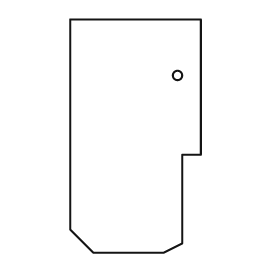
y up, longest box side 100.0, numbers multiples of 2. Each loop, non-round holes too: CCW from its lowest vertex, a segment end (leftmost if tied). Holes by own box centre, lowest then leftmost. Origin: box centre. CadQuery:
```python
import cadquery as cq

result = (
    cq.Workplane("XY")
    .moveTo(-18.0, -50.0)
    .lineTo(12.0, -50.0)
    .lineTo(20.0, -46.0)
    .lineTo(20.0, -8.0)
    .lineTo(28.0, -8.0)
    .lineTo(28.0, 50.0)
    .lineTo(-28.0, 50.0)
    .lineTo(-28.0, -40.0)
    .close()
    .moveTo(18.0, 26.0)
    .circle(2.0)
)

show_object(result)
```